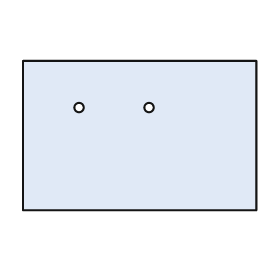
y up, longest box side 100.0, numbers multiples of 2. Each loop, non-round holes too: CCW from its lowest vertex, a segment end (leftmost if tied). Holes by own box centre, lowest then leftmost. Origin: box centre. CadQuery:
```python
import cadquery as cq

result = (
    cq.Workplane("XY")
    .moveTo(-50.0, -32.0)
    .lineTo(50.0, -32.0)
    .lineTo(50.0, 32.0)
    .lineTo(-50.0, 32.0)
    .close()
    .moveTo(-26.0, 12.0)
    .circle(2.0)
    .moveTo(4.0, 12.0)
    .circle(2.0)
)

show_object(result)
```